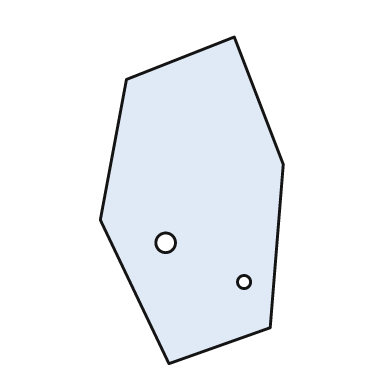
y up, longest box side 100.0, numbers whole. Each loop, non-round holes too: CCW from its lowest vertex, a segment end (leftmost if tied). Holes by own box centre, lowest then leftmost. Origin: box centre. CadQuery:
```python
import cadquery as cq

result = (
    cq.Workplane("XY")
    .moveTo(-7.0, -50.0)
    .lineTo(24.0, -39.0)
    .lineTo(28.0, 11.0)
    .lineTo(13.0, 50.0)
    .lineTo(-20.0, 37.0)
    .lineTo(-28.0, -6.0)
    .close()
    .moveTo(16.0, -25.0)
    .circle(2.0)
    .moveTo(-8.0, -13.0)
    .circle(3.0)
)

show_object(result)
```